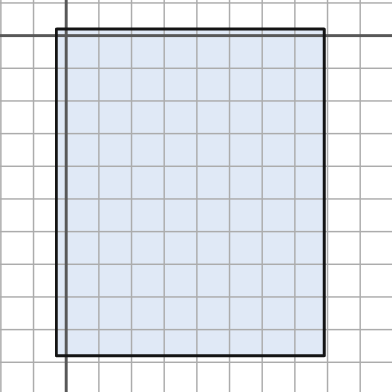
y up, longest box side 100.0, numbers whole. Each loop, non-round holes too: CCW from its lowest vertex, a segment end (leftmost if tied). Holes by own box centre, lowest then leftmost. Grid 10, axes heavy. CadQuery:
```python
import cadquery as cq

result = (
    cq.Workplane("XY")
    .moveTo(-3.0, -98.0)
    .lineTo(79.0, -98.0)
    .lineTo(79.0, 2.0)
    .lineTo(-3.0, 2.0)
    .close()
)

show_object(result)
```